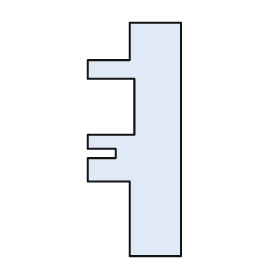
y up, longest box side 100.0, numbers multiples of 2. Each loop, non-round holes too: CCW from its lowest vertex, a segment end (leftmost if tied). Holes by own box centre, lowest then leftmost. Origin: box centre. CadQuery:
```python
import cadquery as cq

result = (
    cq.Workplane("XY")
    .moveTo(-2.0, -50.0)
    .lineTo(20.0, -50.0)
    .lineTo(20.0, 50.0)
    .lineTo(-2.0, 50.0)
    .lineTo(-2.0, 34.0)
    .lineTo(-20.0, 34.0)
    .lineTo(-20.0, 26.0)
    .lineTo(0.0, 26.0)
    .lineTo(0.0, 2.0)
    .lineTo(-20.0, 2.0)
    .lineTo(-20.0, -4.0)
    .lineTo(-8.0, -4.0)
    .lineTo(-8.0, -8.0)
    .lineTo(-20.0, -8.0)
    .lineTo(-20.0, -18.0)
    .lineTo(-2.0, -18.0)
    .close()
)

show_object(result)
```